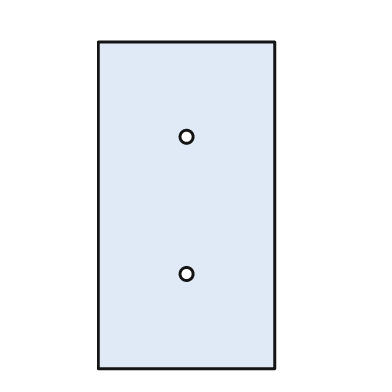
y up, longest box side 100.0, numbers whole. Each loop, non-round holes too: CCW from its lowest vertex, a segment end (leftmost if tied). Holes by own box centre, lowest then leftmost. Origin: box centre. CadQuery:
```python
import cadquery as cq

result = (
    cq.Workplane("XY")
    .moveTo(-27.0, -50.0)
    .lineTo(27.0, -50.0)
    .lineTo(27.0, 50.0)
    .lineTo(-27.0, 50.0)
    .close()
    .moveTo(0.0, -21.0)
    .circle(2.0)
    .moveTo(0.0, 21.0)
    .circle(2.0)
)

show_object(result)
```